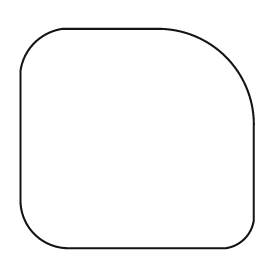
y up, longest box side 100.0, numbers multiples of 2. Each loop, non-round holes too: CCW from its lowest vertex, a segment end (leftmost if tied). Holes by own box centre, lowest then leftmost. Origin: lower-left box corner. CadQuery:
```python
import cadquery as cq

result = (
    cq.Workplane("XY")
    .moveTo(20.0, 0.0)
    .lineTo(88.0, 0.0)
    .threePointArc((96.0, 4.0), (100.0, 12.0))
    .lineTo(100.0, 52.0)
    .threePointArc((88.0, 82.0), (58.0, 94.0))
    .lineTo(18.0, 94.0)
    .threePointArc((6.0, 88.0), (0.0, 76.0))
    .lineTo(0.0, 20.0)
    .threePointArc((6.0, 6.0), (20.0, 0.0))
    .close()
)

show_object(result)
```